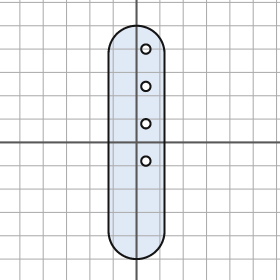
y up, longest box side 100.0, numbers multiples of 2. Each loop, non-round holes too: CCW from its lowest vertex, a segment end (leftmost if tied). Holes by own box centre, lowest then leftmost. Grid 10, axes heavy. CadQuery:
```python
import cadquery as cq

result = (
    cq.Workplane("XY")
    .moveTo(-12.0, -38.0)
    .threePointArc((0.0, -50.0), (12.0, -38.0))
    .lineTo(12.0, 38.0)
    .threePointArc((0.0, 50.0), (-12.0, 38.0))
    .close()
    .moveTo(4.0, -8.0)
    .circle(2.0)
    .moveTo(4.0, 8.0)
    .circle(2.0)
    .moveTo(4.0, 24.0)
    .circle(2.0)
    .moveTo(4.0, 40.0)
    .circle(2.0)
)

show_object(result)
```